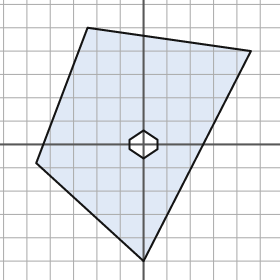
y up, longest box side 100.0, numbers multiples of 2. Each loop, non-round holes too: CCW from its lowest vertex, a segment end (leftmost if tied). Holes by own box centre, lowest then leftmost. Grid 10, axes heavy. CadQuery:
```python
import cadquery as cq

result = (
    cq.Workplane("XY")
    .moveTo(0.0, -50.0)
    .lineTo(46.0, 40.0)
    .lineTo(-24.0, 50.0)
    .lineTo(-46.0, -8.0)
    .close()
    .moveTo(0.0, -6.0)
    .lineTo(6.0, -2.0)
    .lineTo(6.0, 2.0)
    .lineTo(0.0, 6.0)
    .lineTo(-6.0, 2.0)
    .lineTo(-6.0, -2.0)
    .close()
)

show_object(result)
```